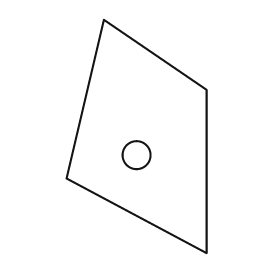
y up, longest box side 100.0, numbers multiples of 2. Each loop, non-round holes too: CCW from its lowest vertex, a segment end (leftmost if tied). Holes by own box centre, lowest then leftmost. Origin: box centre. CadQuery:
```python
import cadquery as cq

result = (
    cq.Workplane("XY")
    .moveTo(30.0, -50.0)
    .lineTo(30.0, 20.0)
    .lineTo(-14.0, 50.0)
    .lineTo(-30.0, -18.0)
    .close()
    .moveTo(0.0, -8.0)
    .circle(6.0)
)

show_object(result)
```